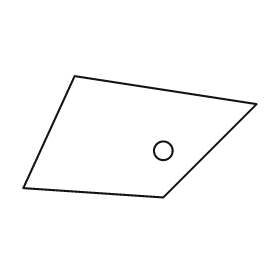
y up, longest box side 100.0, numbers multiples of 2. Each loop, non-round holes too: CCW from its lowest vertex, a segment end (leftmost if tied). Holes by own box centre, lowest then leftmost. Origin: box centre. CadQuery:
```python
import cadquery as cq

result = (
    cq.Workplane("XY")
    .moveTo(10.0, -26.0)
    .lineTo(50.0, 14.0)
    .lineTo(-28.0, 26.0)
    .lineTo(-50.0, -22.0)
    .close()
    .moveTo(10.0, -6.0)
    .circle(4.0)
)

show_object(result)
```